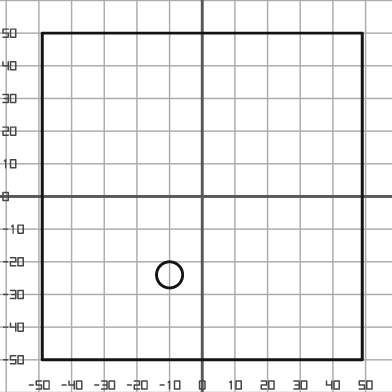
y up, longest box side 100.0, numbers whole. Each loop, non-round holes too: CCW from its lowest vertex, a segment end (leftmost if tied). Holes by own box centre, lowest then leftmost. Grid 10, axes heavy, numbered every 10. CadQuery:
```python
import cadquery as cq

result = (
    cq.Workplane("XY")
    .moveTo(-49.0, -50.0)
    .lineTo(49.0, -50.0)
    .lineTo(49.0, 50.0)
    .lineTo(-49.0, 50.0)
    .close()
    .moveTo(-10.0, -24.0)
    .circle(4.0)
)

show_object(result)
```